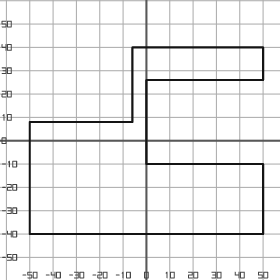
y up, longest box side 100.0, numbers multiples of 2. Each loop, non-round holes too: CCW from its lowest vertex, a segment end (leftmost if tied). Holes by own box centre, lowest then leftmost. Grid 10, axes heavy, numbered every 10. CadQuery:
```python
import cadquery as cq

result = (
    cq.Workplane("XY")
    .moveTo(-50.0, -40.0)
    .lineTo(50.0, -40.0)
    .lineTo(50.0, -10.0)
    .lineTo(0.0, -10.0)
    .lineTo(0.0, 26.0)
    .lineTo(50.0, 26.0)
    .lineTo(50.0, 40.0)
    .lineTo(-6.0, 40.0)
    .lineTo(-6.0, 8.0)
    .lineTo(-50.0, 8.0)
    .close()
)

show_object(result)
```